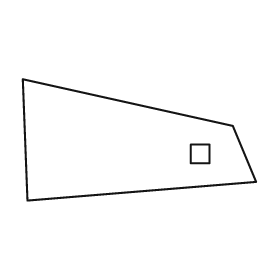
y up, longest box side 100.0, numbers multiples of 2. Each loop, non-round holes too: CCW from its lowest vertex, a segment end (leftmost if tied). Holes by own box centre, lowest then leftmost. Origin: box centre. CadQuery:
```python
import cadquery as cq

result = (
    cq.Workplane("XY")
    .moveTo(-48.0, -26.0)
    .lineTo(50.0, -18.0)
    .lineTo(40.0, 6.0)
    .lineTo(-50.0, 26.0)
    .close()
    .moveTo(22.0, -10.0)
    .lineTo(30.0, -10.0)
    .lineTo(30.0, -2.0)
    .lineTo(22.0, -2.0)
    .close()
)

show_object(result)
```